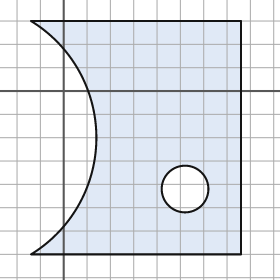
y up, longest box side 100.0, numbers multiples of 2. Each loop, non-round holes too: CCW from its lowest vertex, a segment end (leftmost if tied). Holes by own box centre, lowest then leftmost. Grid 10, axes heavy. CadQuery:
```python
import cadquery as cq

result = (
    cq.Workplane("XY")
    .moveTo(-14.0, -70.0)
    .lineTo(76.0, -70.0)
    .lineTo(76.0, 30.0)
    .lineTo(-14.0, 30.0)
    .threePointArc((14.0, -20.0), (-14.0, -70.0))
    .close()
    .moveTo(52.0, -42.0)
    .circle(10.0)
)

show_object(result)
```